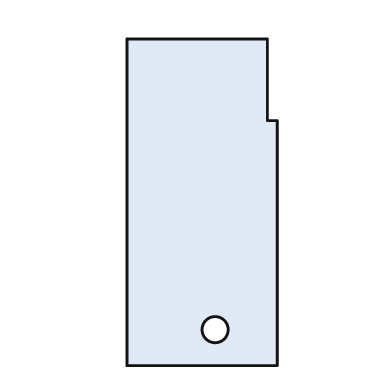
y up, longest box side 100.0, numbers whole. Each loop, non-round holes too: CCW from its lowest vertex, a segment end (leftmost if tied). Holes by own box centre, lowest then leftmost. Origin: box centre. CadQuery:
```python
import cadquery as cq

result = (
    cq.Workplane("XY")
    .moveTo(-23.0, -50.0)
    .lineTo(23.0, -50.0)
    .lineTo(23.0, 25.0)
    .lineTo(20.0, 25.0)
    .lineTo(20.0, 50.0)
    .lineTo(-23.0, 50.0)
    .close()
    .moveTo(4.0, -39.0)
    .circle(4.0)
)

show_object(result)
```